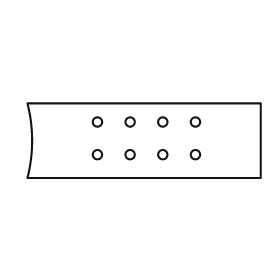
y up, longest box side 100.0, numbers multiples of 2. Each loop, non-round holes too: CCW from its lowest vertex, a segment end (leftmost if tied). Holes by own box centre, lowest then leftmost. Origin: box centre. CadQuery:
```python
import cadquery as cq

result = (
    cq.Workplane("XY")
    .moveTo(-50.0, -16.0)
    .lineTo(50.0, -16.0)
    .lineTo(50.0, 16.0)
    .lineTo(-50.0, 16.0)
    .threePointArc((-48.0, 0.0), (-50.0, -16.0))
    .close()
    .moveTo(-20.0, -6.0)
    .circle(2.0)
    .moveTo(-6.0, -6.0)
    .circle(2.0)
    .moveTo(8.0, -6.0)
    .circle(2.0)
    .moveTo(22.0, -6.0)
    .circle(2.0)
    .moveTo(-20.0, 8.0)
    .circle(2.0)
    .moveTo(-6.0, 8.0)
    .circle(2.0)
    .moveTo(8.0, 8.0)
    .circle(2.0)
    .moveTo(22.0, 8.0)
    .circle(2.0)
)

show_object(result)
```